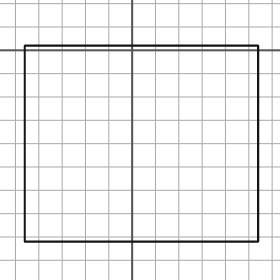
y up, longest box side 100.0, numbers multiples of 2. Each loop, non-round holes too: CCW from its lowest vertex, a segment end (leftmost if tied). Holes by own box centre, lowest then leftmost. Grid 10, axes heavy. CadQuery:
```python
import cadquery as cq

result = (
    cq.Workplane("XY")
    .moveTo(-46.0, -82.0)
    .lineTo(54.0, -82.0)
    .lineTo(54.0, 2.0)
    .lineTo(-46.0, 2.0)
    .close()
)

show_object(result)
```